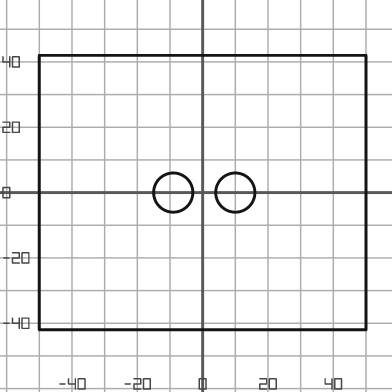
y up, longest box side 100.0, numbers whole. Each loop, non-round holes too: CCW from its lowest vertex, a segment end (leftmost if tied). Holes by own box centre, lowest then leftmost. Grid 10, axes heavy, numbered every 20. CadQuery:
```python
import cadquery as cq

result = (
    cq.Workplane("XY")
    .moveTo(-50.0, -42.0)
    .lineTo(50.0, -42.0)
    .lineTo(50.0, 42.0)
    .lineTo(-50.0, 42.0)
    .close()
    .moveTo(-9.0, 0.0)
    .circle(6.0)
    .moveTo(10.0, 0.0)
    .circle(6.0)
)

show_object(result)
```